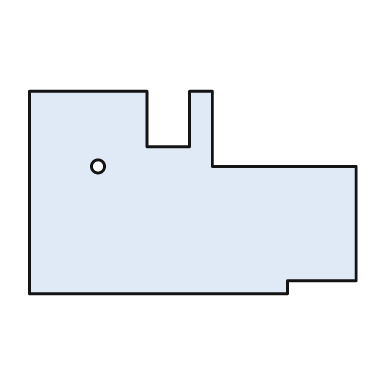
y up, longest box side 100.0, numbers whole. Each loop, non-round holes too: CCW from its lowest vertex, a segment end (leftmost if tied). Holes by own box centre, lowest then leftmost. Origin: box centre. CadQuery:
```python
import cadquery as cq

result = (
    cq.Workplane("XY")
    .moveTo(-50.0, -31.0)
    .lineTo(29.0, -31.0)
    .lineTo(29.0, -27.0)
    .lineTo(50.0, -27.0)
    .lineTo(50.0, 8.0)
    .lineTo(6.0, 8.0)
    .lineTo(6.0, 31.0)
    .lineTo(-1.0, 31.0)
    .lineTo(-1.0, 14.0)
    .lineTo(-14.0, 14.0)
    .lineTo(-14.0, 31.0)
    .lineTo(-50.0, 31.0)
    .close()
    .moveTo(-29.0, 8.0)
    .circle(2.0)
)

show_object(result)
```